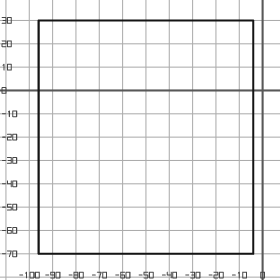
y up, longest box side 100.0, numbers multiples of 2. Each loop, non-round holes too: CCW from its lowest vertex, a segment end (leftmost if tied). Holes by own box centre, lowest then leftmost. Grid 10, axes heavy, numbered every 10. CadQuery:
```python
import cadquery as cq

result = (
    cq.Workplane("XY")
    .moveTo(-96.0, -70.0)
    .lineTo(-4.0, -70.0)
    .lineTo(-4.0, 30.0)
    .lineTo(-96.0, 30.0)
    .close()
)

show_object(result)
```